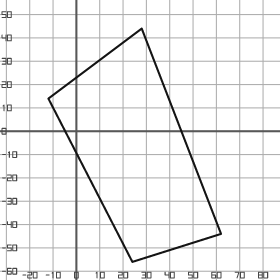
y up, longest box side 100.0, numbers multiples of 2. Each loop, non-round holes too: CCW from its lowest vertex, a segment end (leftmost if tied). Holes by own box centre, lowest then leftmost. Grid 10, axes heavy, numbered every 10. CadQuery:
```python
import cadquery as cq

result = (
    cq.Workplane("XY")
    .moveTo(24.0, -56.0)
    .lineTo(62.0, -44.0)
    .lineTo(28.0, 44.0)
    .lineTo(-12.0, 14.0)
    .close()
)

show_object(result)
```